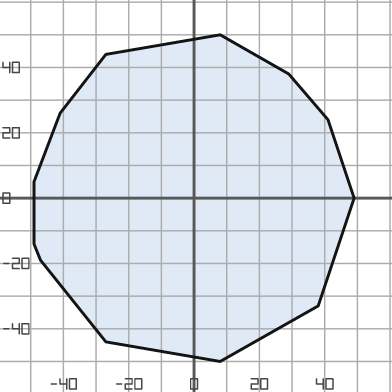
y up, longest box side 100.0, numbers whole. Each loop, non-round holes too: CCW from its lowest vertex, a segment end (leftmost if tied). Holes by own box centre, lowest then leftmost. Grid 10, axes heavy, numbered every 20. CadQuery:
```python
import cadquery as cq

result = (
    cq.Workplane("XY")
    .moveTo(8.0, -50.0)
    .lineTo(38.0, -33.0)
    .lineTo(49.0, 0.0)
    .lineTo(41.0, 24.0)
    .lineTo(29.0, 38.0)
    .lineTo(8.0, 50.0)
    .lineTo(-27.0, 44.0)
    .lineTo(-41.0, 26.0)
    .lineTo(-49.0, 5.0)
    .lineTo(-49.0, -14.0)
    .lineTo(-47.0, -19.0)
    .lineTo(-27.0, -44.0)
    .close()
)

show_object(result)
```